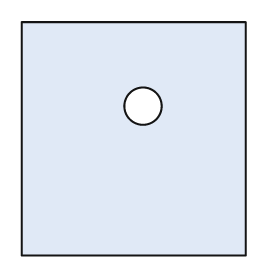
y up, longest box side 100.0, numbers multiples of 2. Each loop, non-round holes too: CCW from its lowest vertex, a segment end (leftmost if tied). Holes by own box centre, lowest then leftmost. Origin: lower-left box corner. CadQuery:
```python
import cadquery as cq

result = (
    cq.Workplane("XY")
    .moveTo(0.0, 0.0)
    .lineTo(96.0, 0.0)
    .lineTo(96.0, 100.0)
    .lineTo(0.0, 100.0)
    .close()
    .moveTo(52.0, 64.0)
    .circle(8.0)
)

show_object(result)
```